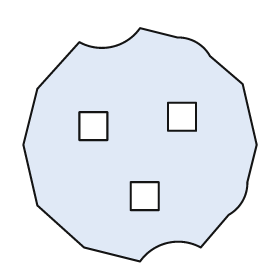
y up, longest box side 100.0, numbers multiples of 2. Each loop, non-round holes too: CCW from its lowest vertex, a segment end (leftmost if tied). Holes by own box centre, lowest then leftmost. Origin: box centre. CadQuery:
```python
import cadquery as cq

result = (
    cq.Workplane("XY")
    .moveTo(0.0, -50.0)
    .threePointArc((12.0, -42.0), (26.0, -44.0))
    .lineTo(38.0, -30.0)
    .threePointArc((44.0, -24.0), (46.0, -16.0))
    .lineTo(50.0, 0.0)
    .lineTo(44.0, 26.0)
    .lineTo(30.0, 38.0)
    .threePointArc((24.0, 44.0), (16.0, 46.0))
    .lineTo(0.0, 50.0)
    .threePointArc((-12.0, 42.0), (-26.0, 44.0))
    .lineTo(-44.0, 24.0)
    .lineTo(-50.0, 0.0)
    .lineTo(-44.0, -26.0)
    .lineTo(-24.0, -44.0)
    .close()
    .moveTo(-4.0, -28.0)
    .lineTo(8.0, -28.0)
    .lineTo(8.0, -16.0)
    .lineTo(-4.0, -16.0)
    .close()
    .moveTo(-26.0, 2.0)
    .lineTo(-14.0, 2.0)
    .lineTo(-14.0, 14.0)
    .lineTo(-26.0, 14.0)
    .close()
    .moveTo(12.0, 6.0)
    .lineTo(24.0, 6.0)
    .lineTo(24.0, 18.0)
    .lineTo(12.0, 18.0)
    .close()
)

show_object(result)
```